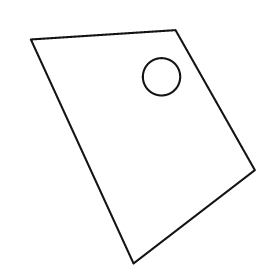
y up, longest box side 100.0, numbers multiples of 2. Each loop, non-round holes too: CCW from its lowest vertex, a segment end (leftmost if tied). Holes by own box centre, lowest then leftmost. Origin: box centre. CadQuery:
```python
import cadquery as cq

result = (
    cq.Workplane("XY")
    .moveTo(-4.0, -50.0)
    .lineTo(48.0, -10.0)
    .lineTo(14.0, 50.0)
    .lineTo(-48.0, 46.0)
    .close()
    .moveTo(8.0, 30.0)
    .circle(8.0)
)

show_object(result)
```